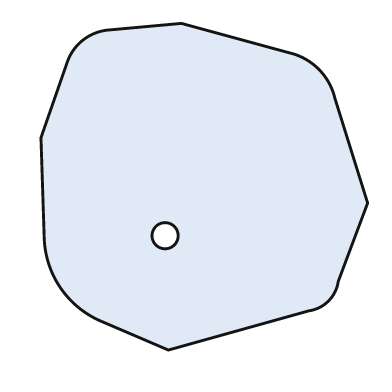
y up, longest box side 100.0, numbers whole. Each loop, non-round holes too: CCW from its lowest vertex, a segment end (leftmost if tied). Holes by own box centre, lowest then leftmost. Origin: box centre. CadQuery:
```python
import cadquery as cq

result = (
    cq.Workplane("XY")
    .moveTo(-11.0, -50.0)
    .lineTo(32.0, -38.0)
    .threePointArc((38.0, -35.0), (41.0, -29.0))
    .lineTo(50.0, -5.0)
    .lineTo(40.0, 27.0)
    .threePointArc((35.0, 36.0), (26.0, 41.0))
    .lineTo(-7.0, 50.0)
    .lineTo(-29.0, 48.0)
    .threePointArc((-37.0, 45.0), (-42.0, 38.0))
    .lineTo(-50.0, 15.0)
    .lineTo(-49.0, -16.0)
    .threePointArc((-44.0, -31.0), (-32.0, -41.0))
    .close()
    .moveTo(-12.0, -15.0)
    .circle(4.0)
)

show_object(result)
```